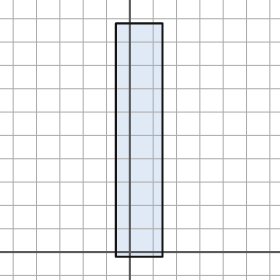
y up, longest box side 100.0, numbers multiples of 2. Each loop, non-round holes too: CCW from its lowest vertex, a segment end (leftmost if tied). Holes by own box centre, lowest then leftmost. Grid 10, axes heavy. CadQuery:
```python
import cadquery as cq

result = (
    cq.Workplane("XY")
    .moveTo(-6.0, -2.0)
    .lineTo(14.0, -2.0)
    .lineTo(14.0, 98.0)
    .lineTo(-6.0, 98.0)
    .close()
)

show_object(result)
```